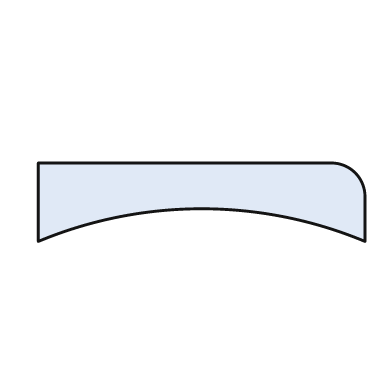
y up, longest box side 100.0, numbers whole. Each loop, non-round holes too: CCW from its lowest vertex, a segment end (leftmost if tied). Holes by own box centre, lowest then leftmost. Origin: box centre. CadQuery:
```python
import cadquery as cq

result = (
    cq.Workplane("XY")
    .moveTo(-50.0, -12.0)
    .threePointArc((0.0, -2.0), (50.0, -12.0))
    .lineTo(50.0, 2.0)
    .threePointArc((47.0, 9.0), (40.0, 12.0))
    .lineTo(-50.0, 12.0)
    .close()
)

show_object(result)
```